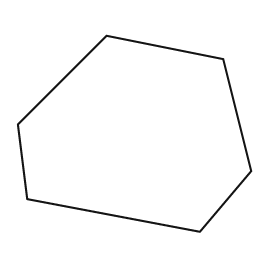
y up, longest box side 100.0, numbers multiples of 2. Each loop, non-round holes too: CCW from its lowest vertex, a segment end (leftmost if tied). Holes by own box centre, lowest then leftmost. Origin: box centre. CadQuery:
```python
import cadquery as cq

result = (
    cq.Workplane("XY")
    .moveTo(28.0, -42.0)
    .lineTo(50.0, -16.0)
    .lineTo(38.0, 32.0)
    .lineTo(-12.0, 42.0)
    .lineTo(-50.0, 4.0)
    .lineTo(-46.0, -28.0)
    .close()
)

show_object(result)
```